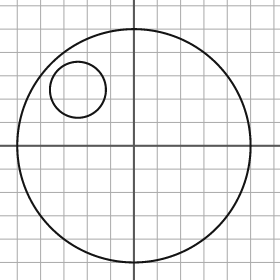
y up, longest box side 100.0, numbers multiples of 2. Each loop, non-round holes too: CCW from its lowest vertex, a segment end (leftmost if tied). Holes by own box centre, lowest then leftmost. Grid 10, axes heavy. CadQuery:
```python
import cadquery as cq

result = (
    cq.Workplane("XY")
    .moveTo(0.0, 0.0)
    .circle(50.0)
    .moveTo(-24.0, 24.0)
    .circle(12.0)
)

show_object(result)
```